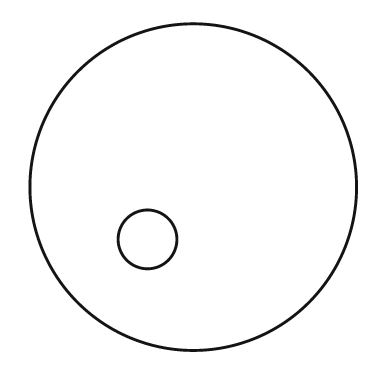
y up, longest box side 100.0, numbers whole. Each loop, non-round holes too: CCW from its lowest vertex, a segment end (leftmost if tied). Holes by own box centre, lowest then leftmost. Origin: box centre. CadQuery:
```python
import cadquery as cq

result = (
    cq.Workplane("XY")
    .moveTo(0.0, 0.0)
    .circle(50.0)
    .moveTo(-14.0, -16.0)
    .circle(9.0)
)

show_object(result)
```